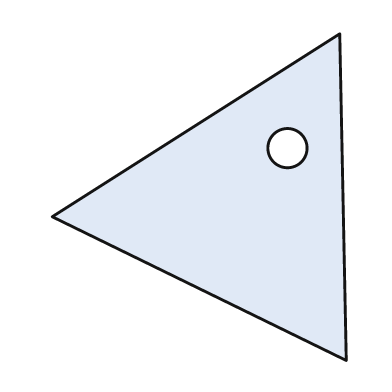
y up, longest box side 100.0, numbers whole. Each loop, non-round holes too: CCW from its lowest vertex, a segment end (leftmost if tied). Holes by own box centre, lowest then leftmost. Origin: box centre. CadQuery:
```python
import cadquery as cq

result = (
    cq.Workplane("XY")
    .moveTo(45.0, -50.0)
    .lineTo(43.0, 50.0)
    .lineTo(-45.0, -6.0)
    .close()
    .moveTo(27.0, 15.0)
    .circle(6.0)
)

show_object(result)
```